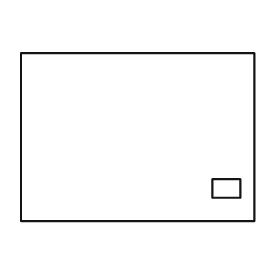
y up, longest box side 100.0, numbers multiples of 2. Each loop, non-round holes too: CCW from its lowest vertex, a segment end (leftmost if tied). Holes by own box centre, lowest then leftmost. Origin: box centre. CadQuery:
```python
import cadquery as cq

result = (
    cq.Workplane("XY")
    .moveTo(-50.0, -36.0)
    .lineTo(50.0, -36.0)
    .lineTo(50.0, 36.0)
    .lineTo(-50.0, 36.0)
    .close()
    .moveTo(32.0, -26.0)
    .lineTo(44.0, -26.0)
    .lineTo(44.0, -18.0)
    .lineTo(32.0, -18.0)
    .close()
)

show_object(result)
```